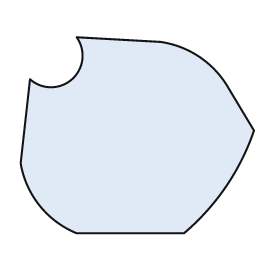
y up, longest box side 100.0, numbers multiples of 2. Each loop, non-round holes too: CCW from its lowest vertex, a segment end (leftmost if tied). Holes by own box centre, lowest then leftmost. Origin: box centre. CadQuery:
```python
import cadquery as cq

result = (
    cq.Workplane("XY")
    .moveTo(-26.0, -42.0)
    .lineTo(20.0, -42.0)
    .threePointArc((38.0, -22.0), (50.0, 2.0))
    .lineTo(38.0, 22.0)
    .threePointArc((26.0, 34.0), (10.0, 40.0))
    .lineTo(-26.0, 42.0)
    .threePointArc((-28.0, 24.0), (-46.0, 24.0))
    .lineTo(-50.0, -12.0)
    .threePointArc((-42.0, -30.0), (-26.0, -42.0))
    .close()
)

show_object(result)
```